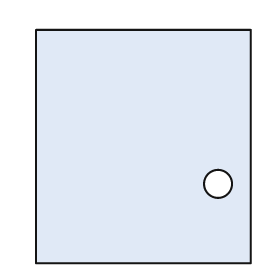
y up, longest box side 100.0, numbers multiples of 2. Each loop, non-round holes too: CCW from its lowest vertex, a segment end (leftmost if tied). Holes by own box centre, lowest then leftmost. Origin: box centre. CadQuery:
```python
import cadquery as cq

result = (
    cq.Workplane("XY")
    .moveTo(-46.0, -50.0)
    .lineTo(46.0, -50.0)
    .lineTo(46.0, 50.0)
    .lineTo(-46.0, 50.0)
    .close()
    .moveTo(32.0, -16.0)
    .circle(6.0)
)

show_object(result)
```